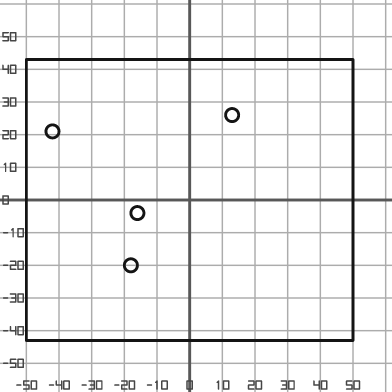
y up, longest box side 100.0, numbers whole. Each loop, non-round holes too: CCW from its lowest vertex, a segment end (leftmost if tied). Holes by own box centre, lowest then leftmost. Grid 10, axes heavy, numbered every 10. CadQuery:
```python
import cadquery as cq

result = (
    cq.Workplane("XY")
    .moveTo(-50.0, -43.0)
    .lineTo(50.0, -43.0)
    .lineTo(50.0, 43.0)
    .lineTo(-50.0, 43.0)
    .close()
    .moveTo(-18.0, -20.0)
    .circle(2.0)
    .moveTo(-16.0, -4.0)
    .circle(2.0)
    .moveTo(-42.0, 21.0)
    .circle(2.0)
    .moveTo(13.0, 26.0)
    .circle(2.0)
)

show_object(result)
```